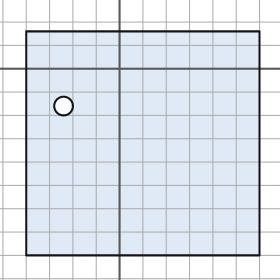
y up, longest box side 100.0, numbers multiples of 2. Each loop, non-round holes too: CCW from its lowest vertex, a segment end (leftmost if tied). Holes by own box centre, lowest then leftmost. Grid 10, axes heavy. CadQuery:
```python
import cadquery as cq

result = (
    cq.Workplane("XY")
    .moveTo(-40.0, -80.0)
    .lineTo(60.0, -80.0)
    .lineTo(60.0, 16.0)
    .lineTo(-40.0, 16.0)
    .close()
    .moveTo(-24.0, -16.0)
    .circle(4.0)
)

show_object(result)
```